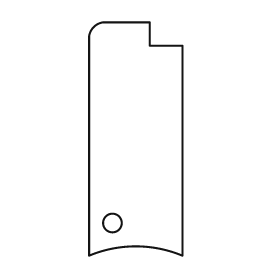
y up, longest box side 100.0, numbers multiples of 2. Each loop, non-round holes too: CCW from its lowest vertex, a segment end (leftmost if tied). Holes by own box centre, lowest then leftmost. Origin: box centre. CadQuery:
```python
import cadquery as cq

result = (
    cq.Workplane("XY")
    .moveTo(-20.0, -50.0)
    .threePointArc((0.0, -46.0), (20.0, -50.0))
    .lineTo(20.0, 40.0)
    .lineTo(6.0, 40.0)
    .lineTo(6.0, 50.0)
    .lineTo(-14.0, 50.0)
    .threePointArc((-18.0, 48.0), (-20.0, 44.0))
    .close()
    .moveTo(-10.0, -36.0)
    .circle(4.0)
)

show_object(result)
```